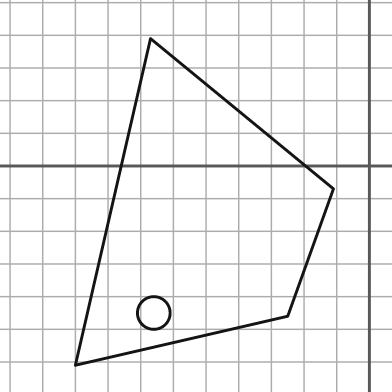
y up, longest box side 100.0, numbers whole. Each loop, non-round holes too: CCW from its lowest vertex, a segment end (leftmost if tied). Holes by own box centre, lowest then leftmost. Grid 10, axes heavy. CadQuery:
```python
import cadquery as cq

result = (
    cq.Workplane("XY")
    .moveTo(-90.0, -61.0)
    .lineTo(-25.0, -46.0)
    .lineTo(-11.0, -7.0)
    .lineTo(-67.0, 39.0)
    .close()
    .moveTo(-66.0, -45.0)
    .circle(5.0)
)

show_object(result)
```